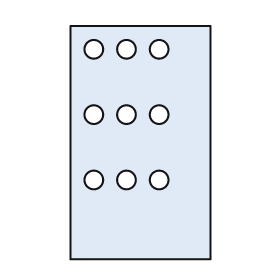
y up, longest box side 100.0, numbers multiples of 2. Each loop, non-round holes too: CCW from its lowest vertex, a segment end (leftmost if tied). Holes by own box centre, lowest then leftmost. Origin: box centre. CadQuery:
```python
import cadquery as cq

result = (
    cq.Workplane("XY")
    .moveTo(-30.0, -50.0)
    .lineTo(30.0, -50.0)
    .lineTo(30.0, 50.0)
    .lineTo(-30.0, 50.0)
    .close()
    .moveTo(-20.0, -16.0)
    .circle(4.0)
    .moveTo(-6.0, -16.0)
    .circle(4.0)
    .moveTo(8.0, -16.0)
    .circle(4.0)
    .moveTo(-20.0, 12.0)
    .circle(4.0)
    .moveTo(-6.0, 12.0)
    .circle(4.0)
    .moveTo(8.0, 12.0)
    .circle(4.0)
    .moveTo(-20.0, 40.0)
    .circle(4.0)
    .moveTo(-6.0, 40.0)
    .circle(4.0)
    .moveTo(8.0, 40.0)
    .circle(4.0)
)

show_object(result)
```